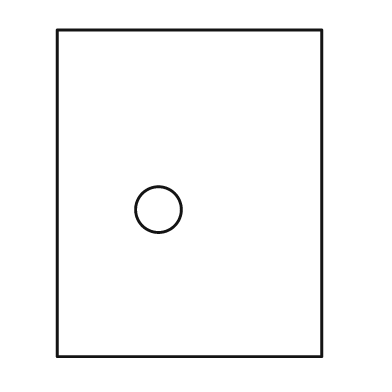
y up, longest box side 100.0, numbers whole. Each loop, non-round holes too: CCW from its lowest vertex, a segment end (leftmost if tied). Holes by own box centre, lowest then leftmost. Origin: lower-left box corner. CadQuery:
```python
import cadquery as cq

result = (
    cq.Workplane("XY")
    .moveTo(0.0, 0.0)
    .lineTo(81.0, 0.0)
    .lineTo(81.0, 100.0)
    .lineTo(0.0, 100.0)
    .close()
    .moveTo(31.0, 45.0)
    .circle(7.0)
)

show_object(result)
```